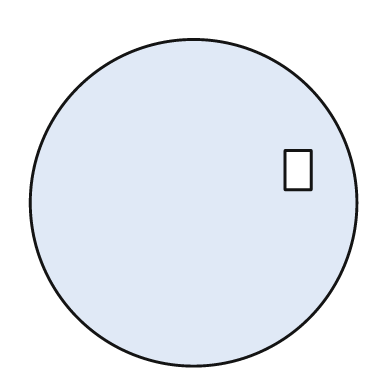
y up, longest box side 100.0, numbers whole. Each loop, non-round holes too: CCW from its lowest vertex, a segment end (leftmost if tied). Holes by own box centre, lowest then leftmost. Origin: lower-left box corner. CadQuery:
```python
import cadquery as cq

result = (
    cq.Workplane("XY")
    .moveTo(50.0, 50.0)
    .circle(50.0)
    .moveTo(78.0, 54.0)
    .lineTo(86.0, 54.0)
    .lineTo(86.0, 66.0)
    .lineTo(78.0, 66.0)
    .close()
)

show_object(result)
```